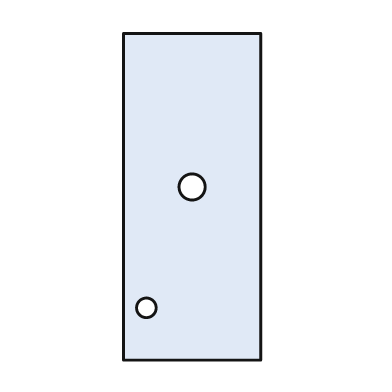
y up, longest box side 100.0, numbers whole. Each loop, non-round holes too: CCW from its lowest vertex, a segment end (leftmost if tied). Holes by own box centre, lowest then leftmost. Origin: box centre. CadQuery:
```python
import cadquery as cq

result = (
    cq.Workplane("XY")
    .moveTo(-21.0, -50.0)
    .lineTo(21.0, -50.0)
    .lineTo(21.0, 50.0)
    .lineTo(-21.0, 50.0)
    .close()
    .moveTo(-14.0, -34.0)
    .circle(3.0)
    .moveTo(0.0, 3.0)
    .circle(4.0)
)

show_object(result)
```